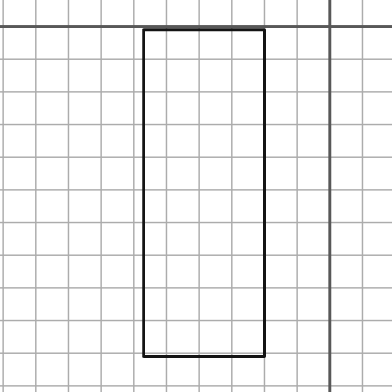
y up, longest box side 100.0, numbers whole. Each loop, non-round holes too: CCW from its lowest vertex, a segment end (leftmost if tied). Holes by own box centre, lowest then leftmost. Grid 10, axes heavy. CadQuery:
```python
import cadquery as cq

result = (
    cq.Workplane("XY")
    .moveTo(-57.0, -101.0)
    .lineTo(-20.0, -101.0)
    .lineTo(-20.0, -1.0)
    .lineTo(-57.0, -1.0)
    .close()
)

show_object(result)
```